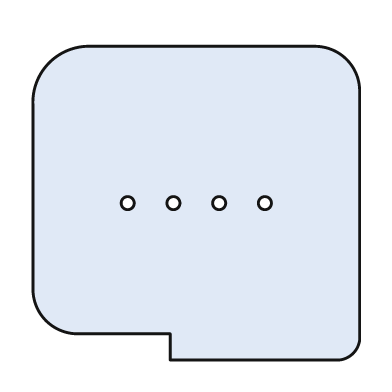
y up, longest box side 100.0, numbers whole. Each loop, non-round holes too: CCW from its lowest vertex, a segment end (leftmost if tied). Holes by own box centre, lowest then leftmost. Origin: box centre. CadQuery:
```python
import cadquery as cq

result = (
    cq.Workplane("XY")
    .moveTo(-8.0, -48.0)
    .lineTo(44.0, -48.0)
    .threePointArc((48.0, -46.0), (50.0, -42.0))
    .lineTo(50.0, 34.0)
    .threePointArc((46.0, 44.0), (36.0, 48.0))
    .lineTo(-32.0, 48.0)
    .threePointArc((-45.0, 43.0), (-50.0, 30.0))
    .lineTo(-50.0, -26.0)
    .threePointArc((-46.0, -36.0), (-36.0, -40.0))
    .lineTo(-8.0, -40.0)
    .close()
    .moveTo(-21.0, 0.0)
    .circle(2.0)
    .moveTo(-7.0, 0.0)
    .circle(2.0)
    .moveTo(7.0, 0.0)
    .circle(2.0)
    .moveTo(21.0, 0.0)
    .circle(2.0)
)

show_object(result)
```